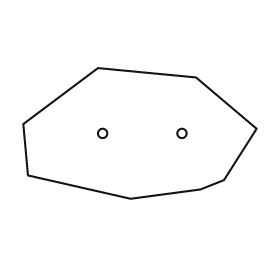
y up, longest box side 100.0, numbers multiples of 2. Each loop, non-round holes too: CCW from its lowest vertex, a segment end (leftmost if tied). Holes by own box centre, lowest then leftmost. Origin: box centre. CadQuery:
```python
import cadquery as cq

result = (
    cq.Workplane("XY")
    .moveTo(-4.0, -28.0)
    .lineTo(26.0, -24.0)
    .lineTo(36.0, -20.0)
    .lineTo(50.0, 2.0)
    .lineTo(24.0, 24.0)
    .lineTo(-18.0, 28.0)
    .lineTo(-50.0, 4.0)
    .lineTo(-48.0, -18.0)
    .close()
    .moveTo(-16.0, 0.0)
    .circle(2.0)
    .moveTo(18.0, 0.0)
    .circle(2.0)
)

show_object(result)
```